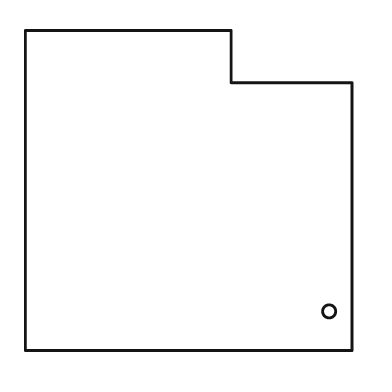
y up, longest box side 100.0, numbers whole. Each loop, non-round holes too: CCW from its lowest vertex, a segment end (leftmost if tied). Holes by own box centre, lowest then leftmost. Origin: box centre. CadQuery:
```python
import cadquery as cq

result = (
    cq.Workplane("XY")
    .moveTo(-50.0, -49.0)
    .lineTo(50.0, -49.0)
    .lineTo(50.0, 33.0)
    .lineTo(13.0, 33.0)
    .lineTo(13.0, 49.0)
    .lineTo(-50.0, 49.0)
    .close()
    .moveTo(43.0, -37.0)
    .circle(2.0)
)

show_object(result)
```